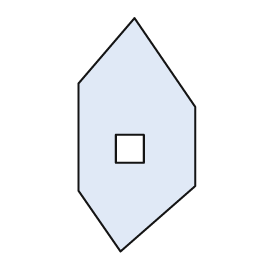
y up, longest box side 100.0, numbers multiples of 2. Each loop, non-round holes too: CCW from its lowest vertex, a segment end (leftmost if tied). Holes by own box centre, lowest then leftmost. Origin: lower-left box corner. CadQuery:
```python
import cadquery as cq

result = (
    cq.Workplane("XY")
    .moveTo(18.0, 0.0)
    .lineTo(50.0, 28.0)
    .lineTo(50.0, 62.0)
    .lineTo(24.0, 100.0)
    .lineTo(0.0, 72.0)
    .lineTo(0.0, 26.0)
    .close()
    .moveTo(16.0, 38.0)
    .lineTo(28.0, 38.0)
    .lineTo(28.0, 50.0)
    .lineTo(16.0, 50.0)
    .close()
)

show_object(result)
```